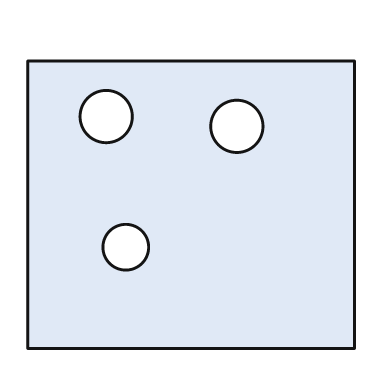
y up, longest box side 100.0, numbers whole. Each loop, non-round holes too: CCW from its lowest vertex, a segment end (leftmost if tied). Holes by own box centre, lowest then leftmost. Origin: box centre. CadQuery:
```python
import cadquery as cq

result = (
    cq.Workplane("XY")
    .moveTo(-50.0, -44.0)
    .lineTo(50.0, -44.0)
    .lineTo(50.0, 44.0)
    .lineTo(-50.0, 44.0)
    .close()
    .moveTo(-20.0, -13.0)
    .circle(7.0)
    .moveTo(14.0, 24.0)
    .circle(8.0)
    .moveTo(-26.0, 27.0)
    .circle(8.0)
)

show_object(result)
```